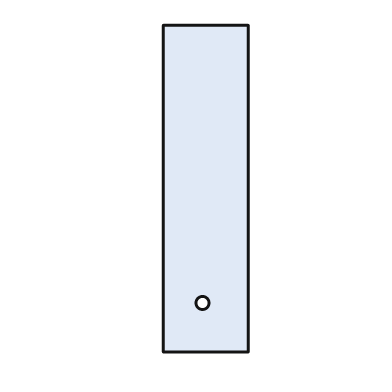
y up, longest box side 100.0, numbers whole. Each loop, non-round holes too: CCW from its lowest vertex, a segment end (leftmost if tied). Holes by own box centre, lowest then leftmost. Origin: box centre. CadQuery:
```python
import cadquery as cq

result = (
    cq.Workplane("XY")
    .moveTo(-13.0, -50.0)
    .lineTo(13.0, -50.0)
    .lineTo(13.0, 50.0)
    .lineTo(-13.0, 50.0)
    .close()
    .moveTo(-1.0, -35.0)
    .circle(2.0)
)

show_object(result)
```